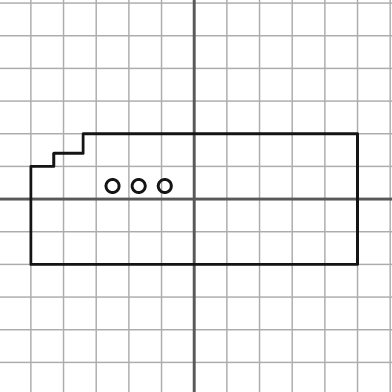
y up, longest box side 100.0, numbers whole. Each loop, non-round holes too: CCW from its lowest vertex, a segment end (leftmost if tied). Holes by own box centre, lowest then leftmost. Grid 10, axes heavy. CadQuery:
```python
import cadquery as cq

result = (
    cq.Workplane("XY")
    .moveTo(-50.0, -20.0)
    .lineTo(50.0, -20.0)
    .lineTo(50.0, 20.0)
    .lineTo(-34.0, 20.0)
    .lineTo(-34.0, 14.0)
    .lineTo(-43.0, 14.0)
    .lineTo(-43.0, 10.0)
    .lineTo(-50.0, 10.0)
    .close()
    .moveTo(-25.0, 4.0)
    .circle(2.0)
    .moveTo(-17.0, 4.0)
    .circle(2.0)
    .moveTo(-9.0, 4.0)
    .circle(2.0)
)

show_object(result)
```